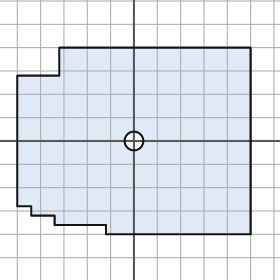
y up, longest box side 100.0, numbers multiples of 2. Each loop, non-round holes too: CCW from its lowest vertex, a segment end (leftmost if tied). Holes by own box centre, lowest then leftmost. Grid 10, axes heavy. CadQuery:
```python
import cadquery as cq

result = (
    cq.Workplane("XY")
    .moveTo(-12.0, -40.0)
    .lineTo(50.0, -40.0)
    .lineTo(50.0, 40.0)
    .lineTo(-32.0, 40.0)
    .lineTo(-32.0, 28.0)
    .lineTo(-50.0, 28.0)
    .lineTo(-50.0, -28.0)
    .lineTo(-44.0, -28.0)
    .lineTo(-44.0, -32.0)
    .lineTo(-34.0, -32.0)
    .lineTo(-34.0, -36.0)
    .lineTo(-12.0, -36.0)
    .close()
    .moveTo(0.0, 0.0)
    .circle(4.0)
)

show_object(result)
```